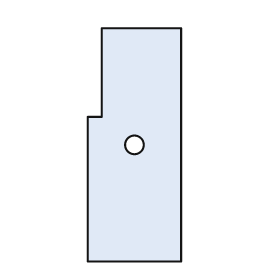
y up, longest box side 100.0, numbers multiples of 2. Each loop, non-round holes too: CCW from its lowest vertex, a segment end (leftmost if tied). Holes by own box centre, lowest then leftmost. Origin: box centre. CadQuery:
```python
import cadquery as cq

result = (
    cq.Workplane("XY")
    .moveTo(-20.0, -50.0)
    .lineTo(20.0, -50.0)
    .lineTo(20.0, 50.0)
    .lineTo(-14.0, 50.0)
    .lineTo(-14.0, 12.0)
    .lineTo(-20.0, 12.0)
    .close()
    .moveTo(0.0, 0.0)
    .circle(4.0)
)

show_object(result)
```